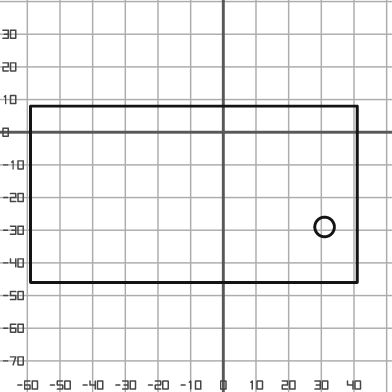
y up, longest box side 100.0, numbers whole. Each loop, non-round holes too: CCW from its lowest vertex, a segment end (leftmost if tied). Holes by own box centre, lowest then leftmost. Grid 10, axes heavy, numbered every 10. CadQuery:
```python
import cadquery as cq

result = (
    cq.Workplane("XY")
    .moveTo(-59.0, -46.0)
    .lineTo(41.0, -46.0)
    .lineTo(41.0, 8.0)
    .lineTo(-59.0, 8.0)
    .close()
    .moveTo(31.0, -29.0)
    .circle(3.0)
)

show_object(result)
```